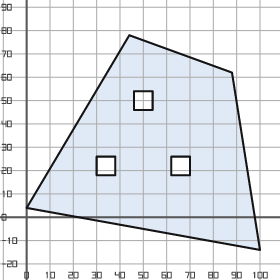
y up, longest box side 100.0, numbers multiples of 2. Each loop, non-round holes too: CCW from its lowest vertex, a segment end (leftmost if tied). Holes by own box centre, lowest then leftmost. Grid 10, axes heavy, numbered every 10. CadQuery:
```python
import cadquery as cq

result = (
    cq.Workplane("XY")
    .moveTo(100.0, -14.0)
    .lineTo(88.0, 62.0)
    .lineTo(44.0, 78.0)
    .lineTo(0.0, 4.0)
    .close()
    .moveTo(30.0, 18.0)
    .lineTo(38.0, 18.0)
    .lineTo(38.0, 26.0)
    .lineTo(30.0, 26.0)
    .close()
    .moveTo(62.0, 18.0)
    .lineTo(70.0, 18.0)
    .lineTo(70.0, 26.0)
    .lineTo(62.0, 26.0)
    .close()
    .moveTo(46.0, 46.0)
    .lineTo(54.0, 46.0)
    .lineTo(54.0, 54.0)
    .lineTo(46.0, 54.0)
    .close()
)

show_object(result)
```